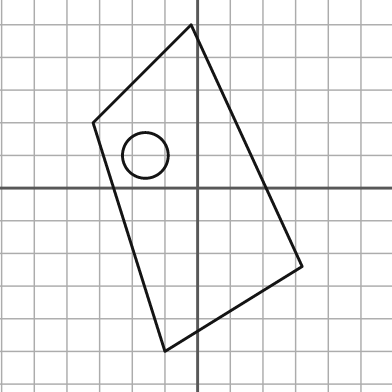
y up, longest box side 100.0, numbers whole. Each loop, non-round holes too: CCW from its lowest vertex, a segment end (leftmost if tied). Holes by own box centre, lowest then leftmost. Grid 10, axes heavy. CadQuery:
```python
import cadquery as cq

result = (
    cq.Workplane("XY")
    .moveTo(-10.0, -50.0)
    .lineTo(32.0, -24.0)
    .lineTo(-2.0, 50.0)
    .lineTo(-32.0, 20.0)
    .close()
    .moveTo(-16.0, 10.0)
    .circle(7.0)
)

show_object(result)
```